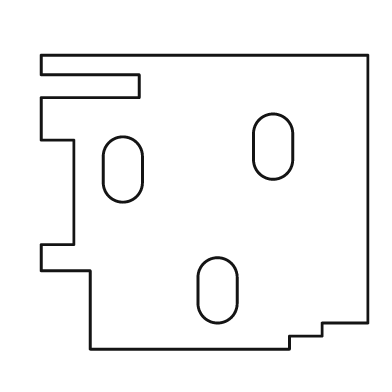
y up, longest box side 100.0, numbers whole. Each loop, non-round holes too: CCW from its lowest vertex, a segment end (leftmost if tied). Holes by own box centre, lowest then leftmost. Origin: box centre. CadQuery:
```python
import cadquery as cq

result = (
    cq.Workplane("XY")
    .moveTo(-35.0, -45.0)
    .lineTo(26.0, -45.0)
    .lineTo(26.0, -41.0)
    .lineTo(36.0, -41.0)
    .lineTo(36.0, -37.0)
    .lineTo(50.0, -37.0)
    .lineTo(50.0, 45.0)
    .lineTo(-50.0, 45.0)
    .lineTo(-50.0, 39.0)
    .lineTo(-20.0, 39.0)
    .lineTo(-20.0, 32.0)
    .lineTo(-50.0, 32.0)
    .lineTo(-50.0, 19.0)
    .lineTo(-40.0, 19.0)
    .lineTo(-40.0, -13.0)
    .lineTo(-50.0, -13.0)
    .lineTo(-50.0, -21.0)
    .lineTo(-35.0, -21.0)
    .close()
    .moveTo(-2.0, -31.0)
    .threePointArc((4.0, -37.0), (10.0, -31.0))
    .lineTo(10.0, -23.0)
    .threePointArc((4.0, -17.0), (-2.0, -23.0))
    .close()
    .moveTo(-31.0, 6.0)
    .threePointArc((-25.0, 0.0), (-19.0, 6.0))
    .lineTo(-19.0, 14.0)
    .threePointArc((-25.0, 20.0), (-31.0, 14.0))
    .close()
    .moveTo(15.0, 13.0)
    .threePointArc((21.0, 7.0), (27.0, 13.0))
    .lineTo(27.0, 21.0)
    .threePointArc((21.0, 27.0), (15.0, 21.0))
    .close()
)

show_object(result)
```